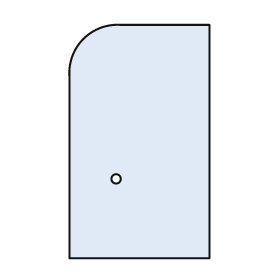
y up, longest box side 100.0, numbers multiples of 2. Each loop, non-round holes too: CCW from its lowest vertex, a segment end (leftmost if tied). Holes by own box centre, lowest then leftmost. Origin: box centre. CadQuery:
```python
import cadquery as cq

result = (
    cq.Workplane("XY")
    .moveTo(-30.0, -50.0)
    .lineTo(30.0, -50.0)
    .lineTo(30.0, 50.0)
    .lineTo(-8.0, 50.0)
    .threePointArc((-24.0, 44.0), (-30.0, 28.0))
    .close()
    .moveTo(-10.0, -16.0)
    .circle(2.0)
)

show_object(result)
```